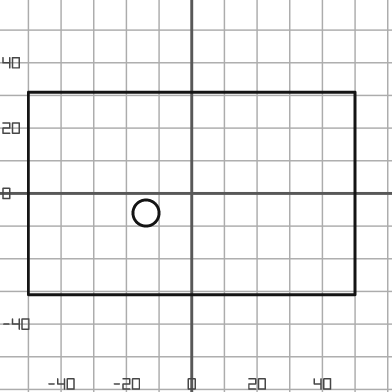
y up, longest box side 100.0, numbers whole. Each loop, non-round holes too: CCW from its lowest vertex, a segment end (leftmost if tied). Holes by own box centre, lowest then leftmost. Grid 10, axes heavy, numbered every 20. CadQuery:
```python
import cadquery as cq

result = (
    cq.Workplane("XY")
    .moveTo(-50.0, -31.0)
    .lineTo(50.0, -31.0)
    .lineTo(50.0, 31.0)
    .lineTo(-50.0, 31.0)
    .close()
    .moveTo(-14.0, -6.0)
    .circle(4.0)
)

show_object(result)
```